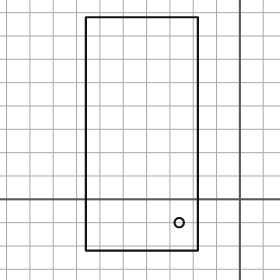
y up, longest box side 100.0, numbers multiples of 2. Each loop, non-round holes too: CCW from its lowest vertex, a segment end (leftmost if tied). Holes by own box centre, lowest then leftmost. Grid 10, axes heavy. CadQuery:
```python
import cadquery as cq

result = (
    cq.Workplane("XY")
    .moveTo(-66.0, -22.0)
    .lineTo(-18.0, -22.0)
    .lineTo(-18.0, 78.0)
    .lineTo(-66.0, 78.0)
    .close()
    .moveTo(-26.0, -10.0)
    .circle(2.0)
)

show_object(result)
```